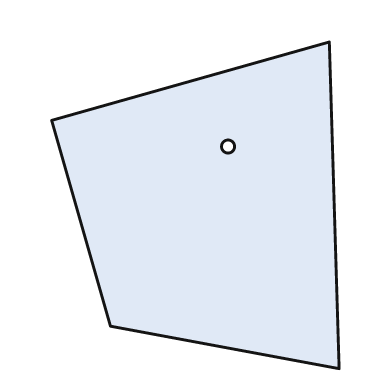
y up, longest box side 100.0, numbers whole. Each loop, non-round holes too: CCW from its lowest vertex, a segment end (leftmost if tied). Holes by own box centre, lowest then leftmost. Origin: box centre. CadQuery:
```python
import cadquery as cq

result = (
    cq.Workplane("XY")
    .moveTo(44.0, -50.0)
    .lineTo(41.0, 50.0)
    .lineTo(-44.0, 26.0)
    .lineTo(-26.0, -37.0)
    .close()
    .moveTo(10.0, 18.0)
    .circle(2.0)
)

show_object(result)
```